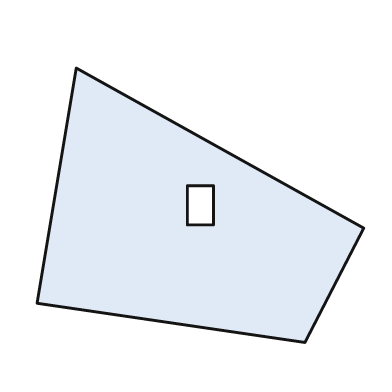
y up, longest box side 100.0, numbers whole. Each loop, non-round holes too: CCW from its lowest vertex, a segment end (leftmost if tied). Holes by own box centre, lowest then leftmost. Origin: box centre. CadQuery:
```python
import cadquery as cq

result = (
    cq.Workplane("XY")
    .moveTo(32.0, -42.0)
    .lineTo(50.0, -7.0)
    .lineTo(-38.0, 42.0)
    .lineTo(-50.0, -30.0)
    .close()
    .moveTo(-4.0, -6.0)
    .lineTo(4.0, -6.0)
    .lineTo(4.0, 6.0)
    .lineTo(-4.0, 6.0)
    .close()
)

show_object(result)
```